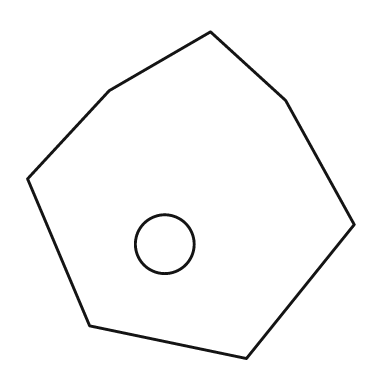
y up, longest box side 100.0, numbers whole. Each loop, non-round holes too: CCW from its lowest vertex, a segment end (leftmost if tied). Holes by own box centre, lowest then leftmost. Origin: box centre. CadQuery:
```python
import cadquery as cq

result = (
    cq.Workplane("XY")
    .moveTo(17.0, -50.0)
    .lineTo(50.0, -9.0)
    .lineTo(29.0, 29.0)
    .lineTo(6.0, 50.0)
    .lineTo(-25.0, 32.0)
    .lineTo(-50.0, 5.0)
    .lineTo(-31.0, -40.0)
    .close()
    .moveTo(-8.0, -15.0)
    .circle(9.0)
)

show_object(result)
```